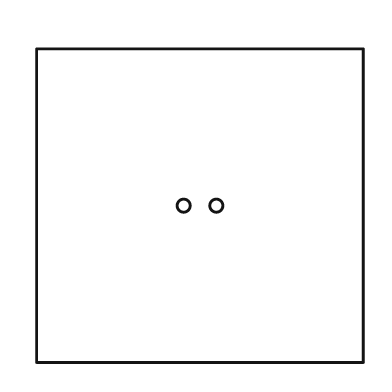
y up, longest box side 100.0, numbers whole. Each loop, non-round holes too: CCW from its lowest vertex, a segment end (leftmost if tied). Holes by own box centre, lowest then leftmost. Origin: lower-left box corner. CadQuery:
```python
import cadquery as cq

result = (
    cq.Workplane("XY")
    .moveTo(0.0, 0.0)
    .lineTo(100.0, 0.0)
    .lineTo(100.0, 96.0)
    .lineTo(0.0, 96.0)
    .close()
    .moveTo(45.0, 48.0)
    .circle(2.0)
    .moveTo(55.0, 48.0)
    .circle(2.0)
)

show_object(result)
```